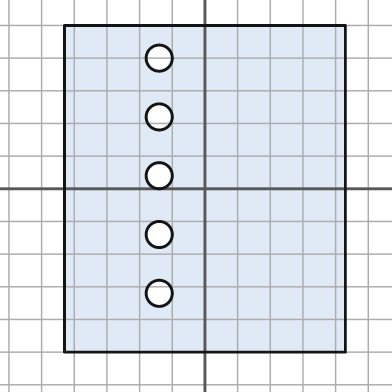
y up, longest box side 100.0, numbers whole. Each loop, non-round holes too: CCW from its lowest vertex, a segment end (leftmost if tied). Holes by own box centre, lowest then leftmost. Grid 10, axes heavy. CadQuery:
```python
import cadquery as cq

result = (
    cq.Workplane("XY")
    .moveTo(-43.0, -50.0)
    .lineTo(43.0, -50.0)
    .lineTo(43.0, 50.0)
    .lineTo(-43.0, 50.0)
    .close()
    .moveTo(-14.0, -32.0)
    .circle(4.0)
    .moveTo(-14.0, -14.0)
    .circle(4.0)
    .moveTo(-14.0, 4.0)
    .circle(4.0)
    .moveTo(-14.0, 22.0)
    .circle(4.0)
    .moveTo(-14.0, 40.0)
    .circle(4.0)
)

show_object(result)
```